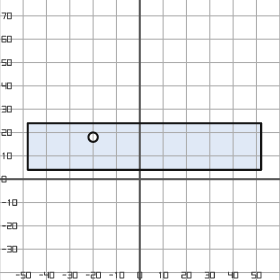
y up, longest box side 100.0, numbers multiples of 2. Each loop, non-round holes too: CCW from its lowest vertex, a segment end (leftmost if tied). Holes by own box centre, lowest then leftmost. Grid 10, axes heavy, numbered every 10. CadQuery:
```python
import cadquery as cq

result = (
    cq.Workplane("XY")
    .moveTo(-48.0, 4.0)
    .lineTo(52.0, 4.0)
    .lineTo(52.0, 24.0)
    .lineTo(-48.0, 24.0)
    .close()
    .moveTo(-20.0, 18.0)
    .circle(2.0)
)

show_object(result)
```